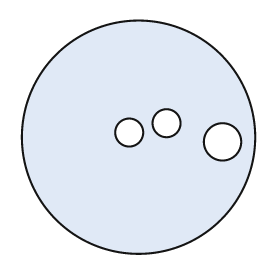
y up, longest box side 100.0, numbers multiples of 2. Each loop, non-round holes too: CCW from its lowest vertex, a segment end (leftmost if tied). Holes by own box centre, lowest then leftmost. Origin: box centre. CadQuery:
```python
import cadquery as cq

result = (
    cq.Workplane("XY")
    .moveTo(0.0, 0.0)
    .circle(50.0)
    .moveTo(36.0, -2.0)
    .circle(8.0)
    .moveTo(-4.0, 2.0)
    .circle(6.0)
    .moveTo(12.0, 6.0)
    .circle(6.0)
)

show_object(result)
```